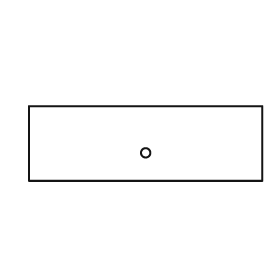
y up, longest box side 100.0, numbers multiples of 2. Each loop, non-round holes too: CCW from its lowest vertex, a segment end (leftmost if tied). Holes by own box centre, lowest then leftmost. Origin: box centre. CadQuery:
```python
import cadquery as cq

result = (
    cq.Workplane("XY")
    .moveTo(-50.0, -16.0)
    .lineTo(50.0, -16.0)
    .lineTo(50.0, 16.0)
    .lineTo(-50.0, 16.0)
    .close()
    .moveTo(0.0, -4.0)
    .circle(2.0)
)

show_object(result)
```